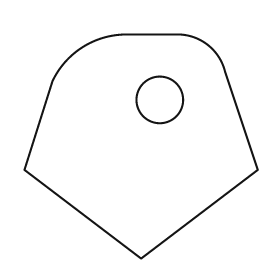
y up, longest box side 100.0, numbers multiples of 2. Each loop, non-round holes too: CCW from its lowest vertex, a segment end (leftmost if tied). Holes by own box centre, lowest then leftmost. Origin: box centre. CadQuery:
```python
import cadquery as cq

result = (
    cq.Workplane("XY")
    .moveTo(0.0, -48.0)
    .lineTo(50.0, -10.0)
    .lineTo(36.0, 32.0)
    .threePointArc((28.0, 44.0), (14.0, 48.0))
    .lineTo(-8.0, 48.0)
    .threePointArc((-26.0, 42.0), (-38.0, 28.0))
    .lineTo(-50.0, -10.0)
    .close()
    .moveTo(8.0, 20.0)
    .circle(10.0)
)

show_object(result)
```